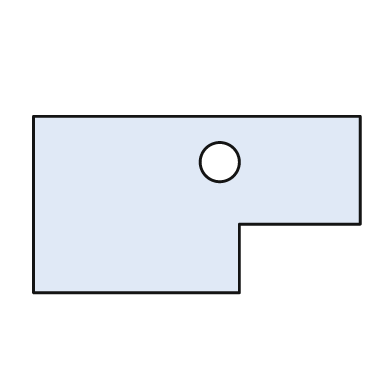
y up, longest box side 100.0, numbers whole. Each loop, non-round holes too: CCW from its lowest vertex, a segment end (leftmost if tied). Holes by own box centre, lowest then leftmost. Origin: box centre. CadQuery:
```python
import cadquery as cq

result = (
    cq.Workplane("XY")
    .moveTo(-50.0, -27.0)
    .lineTo(13.0, -27.0)
    .lineTo(13.0, -6.0)
    .lineTo(50.0, -6.0)
    .lineTo(50.0, 27.0)
    .lineTo(-50.0, 27.0)
    .close()
    .moveTo(7.0, 13.0)
    .circle(6.0)
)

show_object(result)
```